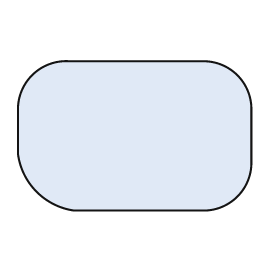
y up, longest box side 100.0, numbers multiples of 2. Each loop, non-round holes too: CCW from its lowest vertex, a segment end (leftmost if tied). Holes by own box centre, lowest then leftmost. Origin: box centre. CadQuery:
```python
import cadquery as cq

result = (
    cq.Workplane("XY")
    .moveTo(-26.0, -32.0)
    .lineTo(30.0, -32.0)
    .threePointArc((44.0, -26.0), (50.0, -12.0))
    .lineTo(50.0, 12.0)
    .threePointArc((44.0, 26.0), (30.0, 32.0))
    .lineTo(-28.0, 32.0)
    .threePointArc((-44.0, 26.0), (-50.0, 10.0))
    .lineTo(-50.0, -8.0)
    .threePointArc((-42.0, -24.0), (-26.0, -32.0))
    .close()
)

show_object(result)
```